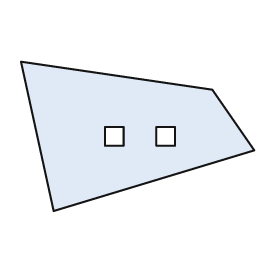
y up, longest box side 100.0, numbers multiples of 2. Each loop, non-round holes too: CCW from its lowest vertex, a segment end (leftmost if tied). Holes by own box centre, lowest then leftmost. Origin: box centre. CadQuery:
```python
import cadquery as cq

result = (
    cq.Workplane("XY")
    .moveTo(-36.0, -32.0)
    .lineTo(50.0, -6.0)
    .lineTo(32.0, 20.0)
    .lineTo(-50.0, 32.0)
    .close()
    .moveTo(-14.0, -4.0)
    .lineTo(-6.0, -4.0)
    .lineTo(-6.0, 4.0)
    .lineTo(-14.0, 4.0)
    .close()
    .moveTo(8.0, -4.0)
    .lineTo(16.0, -4.0)
    .lineTo(16.0, 4.0)
    .lineTo(8.0, 4.0)
    .close()
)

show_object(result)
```